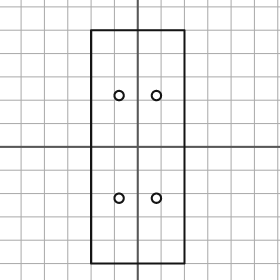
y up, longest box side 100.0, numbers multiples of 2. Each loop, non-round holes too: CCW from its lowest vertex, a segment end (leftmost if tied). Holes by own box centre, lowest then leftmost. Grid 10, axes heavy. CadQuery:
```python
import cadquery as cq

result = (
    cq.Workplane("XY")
    .moveTo(-20.0, -50.0)
    .lineTo(20.0, -50.0)
    .lineTo(20.0, 50.0)
    .lineTo(-20.0, 50.0)
    .close()
    .moveTo(-8.0, -22.0)
    .circle(2.0)
    .moveTo(8.0, -22.0)
    .circle(2.0)
    .moveTo(-8.0, 22.0)
    .circle(2.0)
    .moveTo(8.0, 22.0)
    .circle(2.0)
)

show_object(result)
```